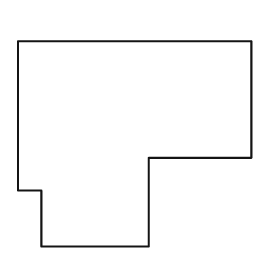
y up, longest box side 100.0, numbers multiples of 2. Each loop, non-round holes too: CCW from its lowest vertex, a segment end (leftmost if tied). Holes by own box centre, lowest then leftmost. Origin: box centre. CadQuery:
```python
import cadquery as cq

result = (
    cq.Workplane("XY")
    .moveTo(-40.0, -44.0)
    .lineTo(6.0, -44.0)
    .lineTo(6.0, -6.0)
    .lineTo(50.0, -6.0)
    .lineTo(50.0, 44.0)
    .lineTo(-50.0, 44.0)
    .lineTo(-50.0, -20.0)
    .lineTo(-40.0, -20.0)
    .close()
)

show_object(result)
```